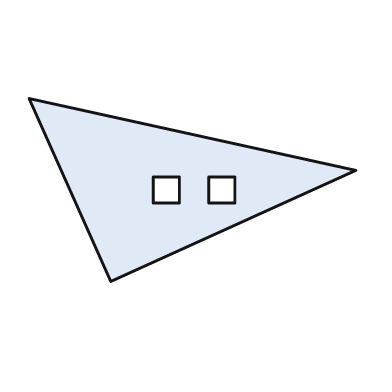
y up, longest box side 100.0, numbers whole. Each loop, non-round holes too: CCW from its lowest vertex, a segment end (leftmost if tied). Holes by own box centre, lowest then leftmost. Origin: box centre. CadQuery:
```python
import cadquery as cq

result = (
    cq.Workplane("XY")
    .moveTo(-25.0, -28.0)
    .lineTo(50.0, 6.0)
    .lineTo(-50.0, 28.0)
    .close()
    .moveTo(-12.0, -4.0)
    .lineTo(-4.0, -4.0)
    .lineTo(-4.0, 4.0)
    .lineTo(-12.0, 4.0)
    .close()
    .moveTo(5.0, -4.0)
    .lineTo(13.0, -4.0)
    .lineTo(13.0, 4.0)
    .lineTo(5.0, 4.0)
    .close()
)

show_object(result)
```